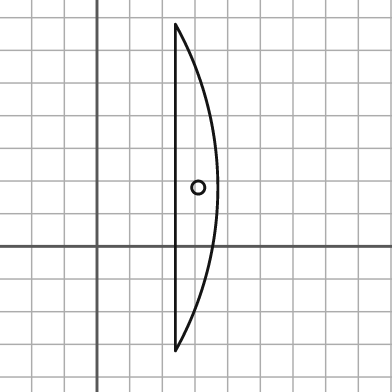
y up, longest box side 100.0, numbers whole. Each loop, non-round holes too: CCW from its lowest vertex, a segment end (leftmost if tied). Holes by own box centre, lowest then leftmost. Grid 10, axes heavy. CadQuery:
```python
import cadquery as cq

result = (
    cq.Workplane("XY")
    .moveTo(24.0, -32.0)
    .threePointArc((37.0, 18.0), (24.0, 68.0))
    .close()
    .moveTo(31.0, 18.0)
    .circle(2.0)
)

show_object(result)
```